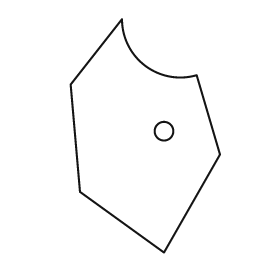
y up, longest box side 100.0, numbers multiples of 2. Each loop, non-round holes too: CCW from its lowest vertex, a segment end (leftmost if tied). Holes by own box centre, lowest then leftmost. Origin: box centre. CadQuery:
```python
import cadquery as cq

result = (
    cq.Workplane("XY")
    .moveTo(8.0, -50.0)
    .lineTo(32.0, -8.0)
    .lineTo(22.0, 26.0)
    .threePointArc((0.0, 30.0), (-10.0, 50.0))
    .lineTo(-32.0, 22.0)
    .lineTo(-28.0, -24.0)
    .close()
    .moveTo(8.0, 2.0)
    .circle(4.0)
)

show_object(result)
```